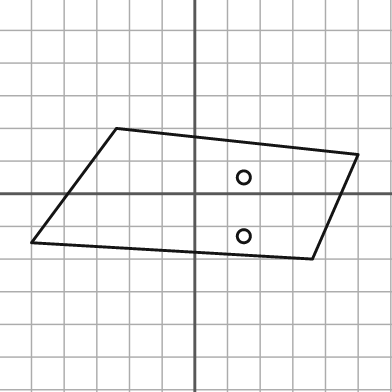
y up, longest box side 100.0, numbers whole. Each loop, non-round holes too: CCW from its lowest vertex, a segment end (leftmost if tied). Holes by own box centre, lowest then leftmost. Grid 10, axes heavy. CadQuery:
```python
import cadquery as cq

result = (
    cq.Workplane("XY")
    .moveTo(36.0, -20.0)
    .lineTo(50.0, 12.0)
    .lineTo(-24.0, 20.0)
    .lineTo(-50.0, -15.0)
    .close()
    .moveTo(15.0, -13.0)
    .circle(2.0)
    .moveTo(15.0, 5.0)
    .circle(2.0)
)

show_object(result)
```